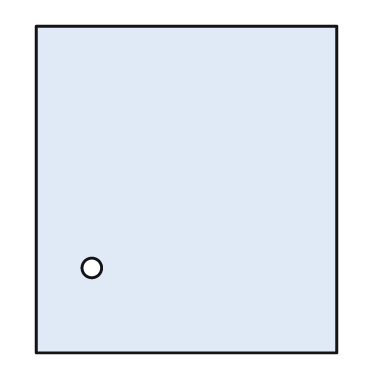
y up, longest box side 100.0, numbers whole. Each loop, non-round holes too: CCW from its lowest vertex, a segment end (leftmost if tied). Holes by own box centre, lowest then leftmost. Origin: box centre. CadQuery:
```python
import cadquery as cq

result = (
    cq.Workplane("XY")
    .moveTo(-46.0, -50.0)
    .lineTo(46.0, -50.0)
    .lineTo(46.0, 50.0)
    .lineTo(-46.0, 50.0)
    .close()
    .moveTo(-29.0, -24.0)
    .circle(3.0)
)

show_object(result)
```